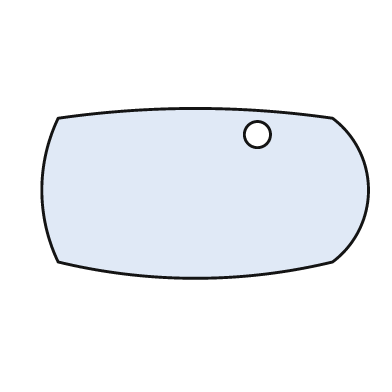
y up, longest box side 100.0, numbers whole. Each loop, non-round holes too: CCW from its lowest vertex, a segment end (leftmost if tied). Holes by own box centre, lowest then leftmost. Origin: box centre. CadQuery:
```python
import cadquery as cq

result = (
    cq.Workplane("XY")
    .moveTo(-45.0, -21.0)
    .threePointArc((-3.0, -26.0), (39.0, -21.0))
    .threePointArc((50.0, 1.0), (39.0, 23.0))
    .threePointArc((-3.0, 26.0), (-45.0, 23.0))
    .threePointArc((-50.0, 1.0), (-45.0, -21.0))
    .close()
    .moveTo(16.0, 18.0)
    .circle(4.0)
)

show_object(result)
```